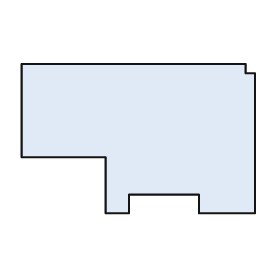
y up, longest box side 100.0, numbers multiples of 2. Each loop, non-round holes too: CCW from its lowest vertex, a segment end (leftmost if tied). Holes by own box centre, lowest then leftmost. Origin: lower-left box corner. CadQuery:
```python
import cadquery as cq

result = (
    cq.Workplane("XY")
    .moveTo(36.0, 0.0)
    .lineTo(46.0, 0.0)
    .lineTo(46.0, 8.0)
    .lineTo(76.0, 8.0)
    .lineTo(76.0, 0.0)
    .lineTo(100.0, 0.0)
    .lineTo(100.0, 60.0)
    .lineTo(96.0, 60.0)
    .lineTo(96.0, 64.0)
    .lineTo(0.0, 64.0)
    .lineTo(0.0, 24.0)
    .lineTo(36.0, 24.0)
    .close()
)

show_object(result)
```